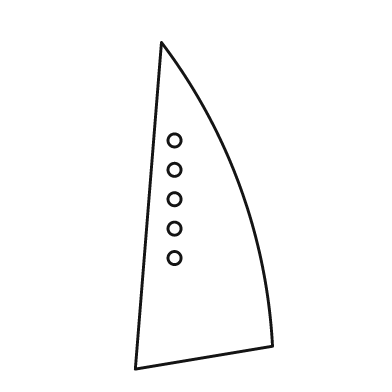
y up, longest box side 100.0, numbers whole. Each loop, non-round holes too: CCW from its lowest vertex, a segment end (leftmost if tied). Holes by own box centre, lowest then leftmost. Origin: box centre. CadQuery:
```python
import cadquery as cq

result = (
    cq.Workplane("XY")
    .moveTo(-21.0, -50.0)
    .lineTo(21.0, -43.0)
    .threePointArc((11.0, 6.0), (-13.0, 50.0))
    .close()
    .moveTo(-9.0, -16.0)
    .circle(2.0)
    .moveTo(-9.0, -7.0)
    .circle(2.0)
    .moveTo(-9.0, 2.0)
    .circle(2.0)
    .moveTo(-9.0, 11.0)
    .circle(2.0)
    .moveTo(-9.0, 20.0)
    .circle(2.0)
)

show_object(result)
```